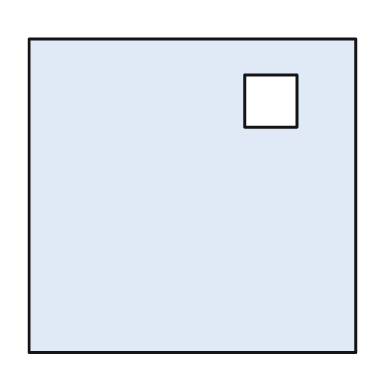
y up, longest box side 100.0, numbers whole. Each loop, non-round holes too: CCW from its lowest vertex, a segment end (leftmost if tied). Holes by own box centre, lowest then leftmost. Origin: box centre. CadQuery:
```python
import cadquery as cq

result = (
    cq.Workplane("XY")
    .moveTo(-50.0, -48.0)
    .lineTo(50.0, -48.0)
    .lineTo(50.0, 48.0)
    .lineTo(-50.0, 48.0)
    .close()
    .moveTo(16.0, 21.0)
    .lineTo(32.0, 21.0)
    .lineTo(32.0, 37.0)
    .lineTo(16.0, 37.0)
    .close()
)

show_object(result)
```